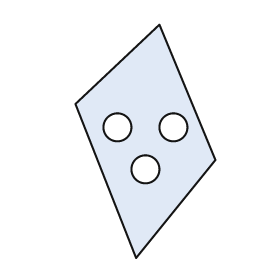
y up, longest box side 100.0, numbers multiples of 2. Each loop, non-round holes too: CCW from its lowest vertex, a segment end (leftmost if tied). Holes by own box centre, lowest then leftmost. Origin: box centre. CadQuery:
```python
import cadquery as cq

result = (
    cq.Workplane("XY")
    .moveTo(-4.0, -50.0)
    .lineTo(30.0, -8.0)
    .lineTo(6.0, 50.0)
    .lineTo(-30.0, 16.0)
    .close()
    .moveTo(0.0, -12.0)
    .circle(6.0)
    .moveTo(-12.0, 6.0)
    .circle(6.0)
    .moveTo(12.0, 6.0)
    .circle(6.0)
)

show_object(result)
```